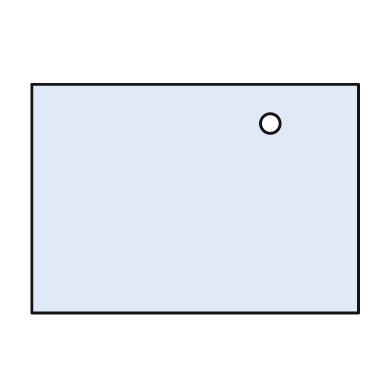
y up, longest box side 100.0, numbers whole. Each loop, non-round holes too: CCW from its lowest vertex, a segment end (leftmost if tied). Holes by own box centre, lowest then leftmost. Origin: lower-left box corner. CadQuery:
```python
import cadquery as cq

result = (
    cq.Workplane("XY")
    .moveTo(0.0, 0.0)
    .lineTo(100.0, 0.0)
    .lineTo(100.0, 70.0)
    .lineTo(0.0, 70.0)
    .close()
    .moveTo(73.0, 58.0)
    .circle(3.0)
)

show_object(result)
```